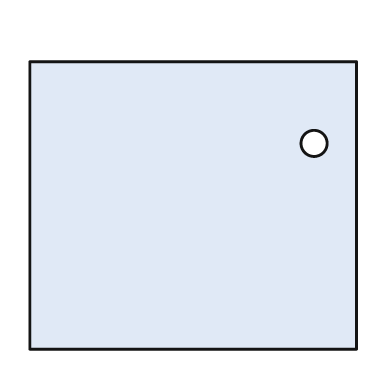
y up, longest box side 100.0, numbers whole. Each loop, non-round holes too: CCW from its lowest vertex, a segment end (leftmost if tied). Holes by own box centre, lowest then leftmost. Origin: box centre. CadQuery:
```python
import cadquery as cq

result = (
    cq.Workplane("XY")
    .moveTo(-50.0, -44.0)
    .lineTo(50.0, -44.0)
    .lineTo(50.0, 44.0)
    .lineTo(-50.0, 44.0)
    .close()
    .moveTo(37.0, 19.0)
    .circle(4.0)
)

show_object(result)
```